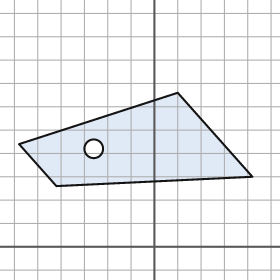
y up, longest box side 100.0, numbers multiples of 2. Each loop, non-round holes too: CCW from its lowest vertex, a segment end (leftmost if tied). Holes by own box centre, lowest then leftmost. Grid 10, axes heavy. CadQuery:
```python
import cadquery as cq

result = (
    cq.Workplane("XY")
    .moveTo(-42.0, 26.0)
    .lineTo(42.0, 30.0)
    .lineTo(10.0, 66.0)
    .lineTo(-58.0, 44.0)
    .close()
    .moveTo(-26.0, 42.0)
    .circle(4.0)
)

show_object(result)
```